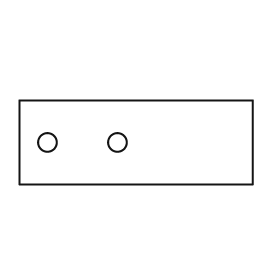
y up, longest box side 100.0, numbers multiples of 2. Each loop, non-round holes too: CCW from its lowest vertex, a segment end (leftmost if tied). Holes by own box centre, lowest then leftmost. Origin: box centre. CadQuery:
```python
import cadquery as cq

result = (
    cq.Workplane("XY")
    .moveTo(-50.0, -18.0)
    .lineTo(50.0, -18.0)
    .lineTo(50.0, 18.0)
    .lineTo(-50.0, 18.0)
    .close()
    .moveTo(-38.0, 0.0)
    .circle(4.0)
    .moveTo(-8.0, 0.0)
    .circle(4.0)
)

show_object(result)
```